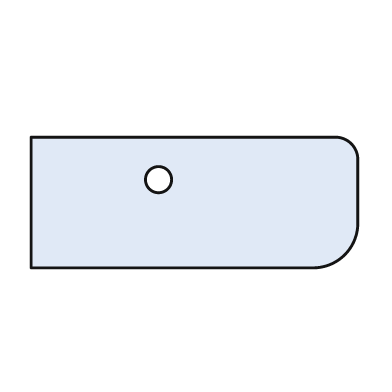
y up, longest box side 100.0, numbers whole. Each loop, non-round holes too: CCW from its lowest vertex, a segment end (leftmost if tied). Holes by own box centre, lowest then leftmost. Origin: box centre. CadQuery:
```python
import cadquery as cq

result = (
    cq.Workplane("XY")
    .moveTo(-50.0, -20.0)
    .lineTo(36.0, -20.0)
    .threePointArc((46.0, -16.0), (50.0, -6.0))
    .lineTo(50.0, 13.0)
    .threePointArc((48.0, 18.0), (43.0, 20.0))
    .lineTo(-50.0, 20.0)
    .close()
    .moveTo(-11.0, 7.0)
    .circle(4.0)
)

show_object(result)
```